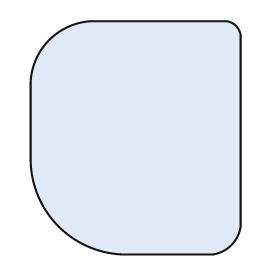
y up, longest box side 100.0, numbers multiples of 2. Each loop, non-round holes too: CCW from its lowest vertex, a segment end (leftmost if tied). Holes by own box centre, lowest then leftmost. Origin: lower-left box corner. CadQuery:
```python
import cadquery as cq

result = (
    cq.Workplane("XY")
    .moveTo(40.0, 0.0)
    .lineTo(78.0, 0.0)
    .threePointArc((86.0, 4.0), (90.0, 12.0))
    .lineTo(90.0, 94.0)
    .threePointArc((88.0, 98.0), (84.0, 100.0))
    .lineTo(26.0, 100.0)
    .threePointArc((8.0, 92.0), (0.0, 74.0))
    .lineTo(0.0, 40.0)
    .threePointArc((12.0, 12.0), (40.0, 0.0))
    .close()
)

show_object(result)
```